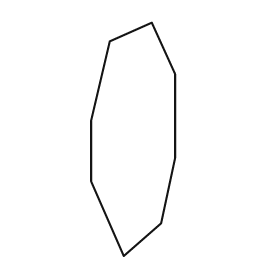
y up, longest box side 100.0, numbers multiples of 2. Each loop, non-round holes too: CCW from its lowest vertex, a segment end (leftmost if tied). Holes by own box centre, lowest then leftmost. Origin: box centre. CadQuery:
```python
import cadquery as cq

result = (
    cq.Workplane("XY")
    .moveTo(-4.0, -50.0)
    .lineTo(12.0, -36.0)
    .lineTo(18.0, -8.0)
    .lineTo(18.0, 28.0)
    .lineTo(8.0, 50.0)
    .lineTo(-10.0, 42.0)
    .lineTo(-18.0, 8.0)
    .lineTo(-18.0, -18.0)
    .close()
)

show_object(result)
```